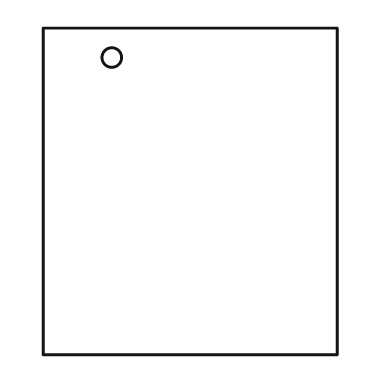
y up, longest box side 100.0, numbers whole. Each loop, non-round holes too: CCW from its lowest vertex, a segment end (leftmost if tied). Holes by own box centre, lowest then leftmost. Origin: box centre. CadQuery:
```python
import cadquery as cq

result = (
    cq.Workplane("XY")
    .moveTo(-45.0, -50.0)
    .lineTo(45.0, -50.0)
    .lineTo(45.0, 50.0)
    .lineTo(-45.0, 50.0)
    .close()
    .moveTo(-24.0, 41.0)
    .circle(3.0)
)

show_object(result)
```